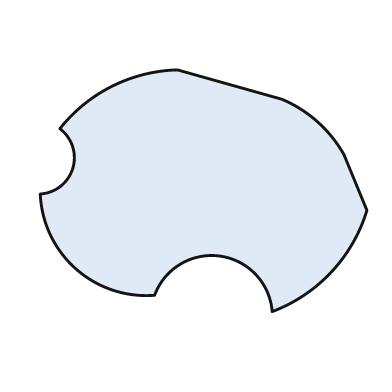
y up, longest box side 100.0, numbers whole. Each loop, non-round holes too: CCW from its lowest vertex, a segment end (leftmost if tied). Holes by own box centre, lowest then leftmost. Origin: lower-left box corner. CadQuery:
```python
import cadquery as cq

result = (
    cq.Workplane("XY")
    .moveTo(71.0, 0.0)
    .threePointArc((89.0, 12.0), (100.0, 31.0))
    .lineTo(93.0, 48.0)
    .threePointArc((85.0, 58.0), (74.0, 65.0))
    .lineTo(42.0, 74.0)
    .threePointArc((22.0, 69.0), (6.0, 56.0))
    .threePointArc((10.0, 44.0), (0.0, 36.0))
    .threePointArc((11.0, 13.0), (35.0, 5.0))
    .threePointArc((55.0, 17.0), (71.0, 0.0))
    .close()
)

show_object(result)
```